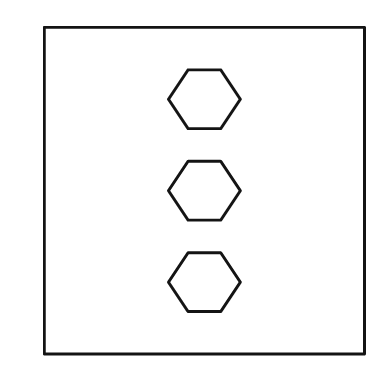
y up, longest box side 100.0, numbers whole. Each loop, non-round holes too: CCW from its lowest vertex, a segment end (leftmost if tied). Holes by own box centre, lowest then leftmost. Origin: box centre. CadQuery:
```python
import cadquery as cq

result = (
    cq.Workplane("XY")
    .moveTo(-49.0, -50.0)
    .lineTo(49.0, -50.0)
    .lineTo(49.0, 50.0)
    .lineTo(-49.0, 50.0)
    .close()
    .moveTo(-5.0, -37.0)
    .lineTo(5.0, -37.0)
    .lineTo(11.0, -28.0)
    .lineTo(5.0, -19.0)
    .lineTo(-5.0, -19.0)
    .lineTo(-11.0, -28.0)
    .close()
    .moveTo(-5.0, -9.0)
    .lineTo(5.0, -9.0)
    .lineTo(11.0, 0.0)
    .lineTo(5.0, 9.0)
    .lineTo(-5.0, 9.0)
    .lineTo(-11.0, 0.0)
    .close()
    .moveTo(-5.0, 19.0)
    .lineTo(5.0, 19.0)
    .lineTo(11.0, 28.0)
    .lineTo(5.0, 37.0)
    .lineTo(-5.0, 37.0)
    .lineTo(-11.0, 28.0)
    .close()
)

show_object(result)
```